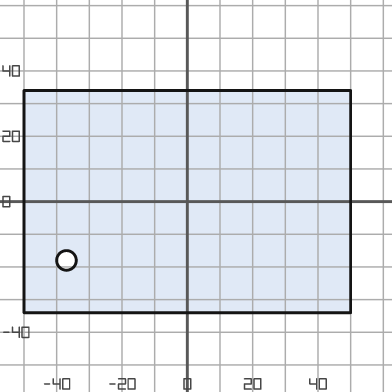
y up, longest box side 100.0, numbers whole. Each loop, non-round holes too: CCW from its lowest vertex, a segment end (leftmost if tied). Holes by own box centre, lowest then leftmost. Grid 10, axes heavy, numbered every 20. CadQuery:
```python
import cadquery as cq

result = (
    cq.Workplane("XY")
    .moveTo(-50.0, -34.0)
    .lineTo(50.0, -34.0)
    .lineTo(50.0, 34.0)
    .lineTo(-50.0, 34.0)
    .close()
    .moveTo(-37.0, -18.0)
    .circle(3.0)
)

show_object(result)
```